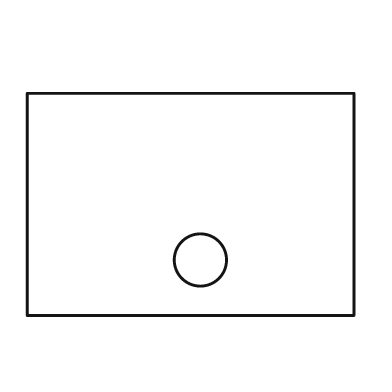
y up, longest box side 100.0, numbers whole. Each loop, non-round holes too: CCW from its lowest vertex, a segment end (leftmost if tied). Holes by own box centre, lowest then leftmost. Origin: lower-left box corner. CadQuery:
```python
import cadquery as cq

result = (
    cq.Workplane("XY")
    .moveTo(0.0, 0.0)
    .lineTo(100.0, 0.0)
    .lineTo(100.0, 68.0)
    .lineTo(0.0, 68.0)
    .close()
    .moveTo(53.0, 17.0)
    .circle(8.0)
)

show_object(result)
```